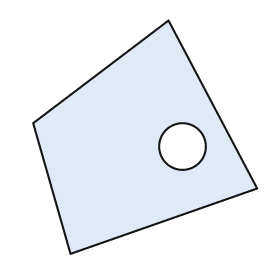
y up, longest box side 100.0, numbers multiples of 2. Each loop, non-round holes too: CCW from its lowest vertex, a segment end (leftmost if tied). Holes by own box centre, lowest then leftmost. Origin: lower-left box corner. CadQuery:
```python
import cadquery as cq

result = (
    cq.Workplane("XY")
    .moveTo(16.0, 0.0)
    .lineTo(96.0, 28.0)
    .lineTo(58.0, 100.0)
    .lineTo(0.0, 56.0)
    .close()
    .moveTo(64.0, 46.0)
    .circle(10.0)
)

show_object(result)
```